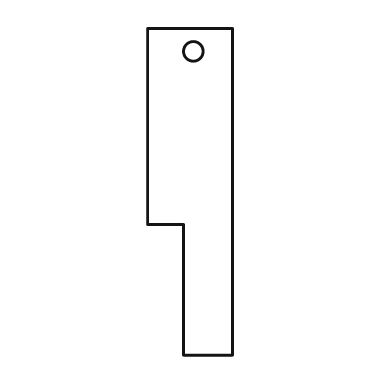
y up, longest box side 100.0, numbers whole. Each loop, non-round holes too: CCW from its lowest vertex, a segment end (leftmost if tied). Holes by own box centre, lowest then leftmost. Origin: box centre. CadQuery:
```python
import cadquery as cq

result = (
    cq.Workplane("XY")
    .moveTo(-2.0, -50.0)
    .lineTo(13.0, -50.0)
    .lineTo(13.0, 50.0)
    .lineTo(-13.0, 50.0)
    .lineTo(-13.0, -10.0)
    .lineTo(-2.0, -10.0)
    .close()
    .moveTo(1.0, 43.0)
    .circle(3.0)
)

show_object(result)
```